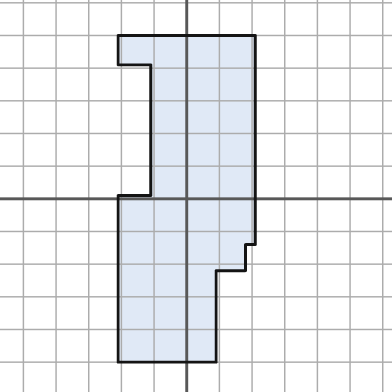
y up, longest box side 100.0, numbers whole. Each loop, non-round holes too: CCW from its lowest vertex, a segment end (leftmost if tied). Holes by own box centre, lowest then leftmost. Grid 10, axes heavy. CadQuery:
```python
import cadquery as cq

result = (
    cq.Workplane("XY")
    .moveTo(-21.0, -50.0)
    .lineTo(9.0, -50.0)
    .lineTo(9.0, -22.0)
    .lineTo(18.0, -22.0)
    .lineTo(18.0, -14.0)
    .lineTo(21.0, -14.0)
    .lineTo(21.0, 50.0)
    .lineTo(-21.0, 50.0)
    .lineTo(-21.0, 41.0)
    .lineTo(-11.0, 41.0)
    .lineTo(-11.0, 1.0)
    .lineTo(-21.0, 1.0)
    .close()
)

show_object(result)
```